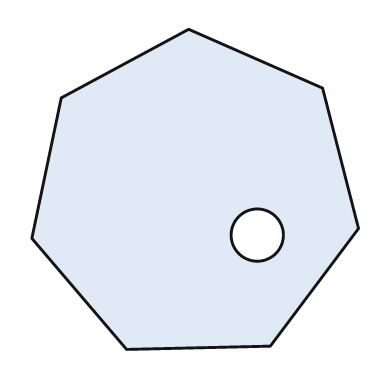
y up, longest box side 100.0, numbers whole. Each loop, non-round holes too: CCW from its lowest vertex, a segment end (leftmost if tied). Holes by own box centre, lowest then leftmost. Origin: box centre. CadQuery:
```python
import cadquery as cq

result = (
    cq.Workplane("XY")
    .moveTo(-21.0, -49.0)
    .lineTo(23.0, -48.0)
    .lineTo(50.0, -12.0)
    .lineTo(39.0, 31.0)
    .lineTo(-2.0, 49.0)
    .lineTo(-41.0, 28.0)
    .lineTo(-50.0, -15.0)
    .close()
    .moveTo(19.0, -14.0)
    .circle(8.0)
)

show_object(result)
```